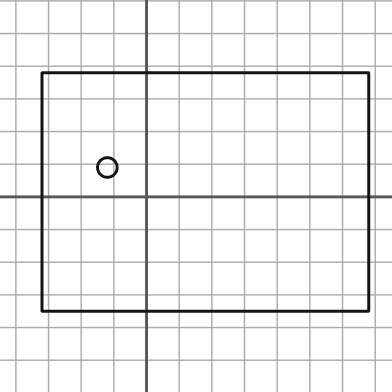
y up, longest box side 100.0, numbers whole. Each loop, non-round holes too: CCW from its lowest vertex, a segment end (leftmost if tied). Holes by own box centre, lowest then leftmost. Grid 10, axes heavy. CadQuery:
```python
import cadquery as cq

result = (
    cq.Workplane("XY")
    .moveTo(-32.0, -35.0)
    .lineTo(68.0, -35.0)
    .lineTo(68.0, 38.0)
    .lineTo(-32.0, 38.0)
    .close()
    .moveTo(-12.0, 9.0)
    .circle(3.0)
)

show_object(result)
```